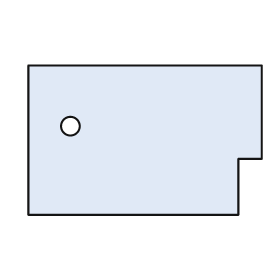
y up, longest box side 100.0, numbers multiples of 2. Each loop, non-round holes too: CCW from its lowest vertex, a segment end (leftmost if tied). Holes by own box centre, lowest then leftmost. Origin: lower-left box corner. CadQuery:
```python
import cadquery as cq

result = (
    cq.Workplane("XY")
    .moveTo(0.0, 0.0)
    .lineTo(90.0, 0.0)
    .lineTo(90.0, 24.0)
    .lineTo(100.0, 24.0)
    .lineTo(100.0, 64.0)
    .lineTo(0.0, 64.0)
    .close()
    .moveTo(18.0, 38.0)
    .circle(4.0)
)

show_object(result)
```